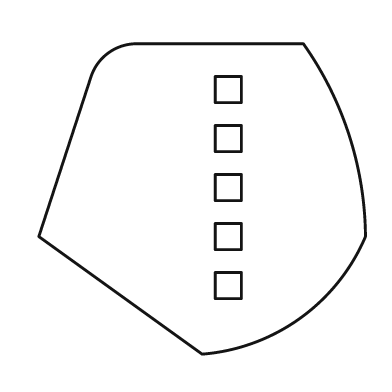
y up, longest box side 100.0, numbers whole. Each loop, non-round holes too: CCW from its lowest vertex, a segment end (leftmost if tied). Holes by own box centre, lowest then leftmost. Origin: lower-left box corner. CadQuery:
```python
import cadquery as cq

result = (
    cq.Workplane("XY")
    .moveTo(50.0, 0.0)
    .threePointArc((80.0, 11.0), (100.0, 36.0))
    .threePointArc((95.0, 67.0), (81.0, 95.0))
    .lineTo(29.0, 95.0)
    .threePointArc((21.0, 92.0), (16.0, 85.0))
    .lineTo(0.0, 36.0)
    .close()
    .moveTo(54.0, 17.0)
    .lineTo(62.0, 17.0)
    .lineTo(62.0, 25.0)
    .lineTo(54.0, 25.0)
    .close()
    .moveTo(54.0, 32.0)
    .lineTo(62.0, 32.0)
    .lineTo(62.0, 40.0)
    .lineTo(54.0, 40.0)
    .close()
    .moveTo(54.0, 47.0)
    .lineTo(62.0, 47.0)
    .lineTo(62.0, 55.0)
    .lineTo(54.0, 55.0)
    .close()
    .moveTo(54.0, 62.0)
    .lineTo(62.0, 62.0)
    .lineTo(62.0, 70.0)
    .lineTo(54.0, 70.0)
    .close()
    .moveTo(54.0, 77.0)
    .lineTo(62.0, 77.0)
    .lineTo(62.0, 85.0)
    .lineTo(54.0, 85.0)
    .close()
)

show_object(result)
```